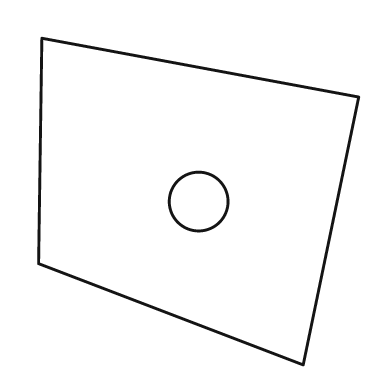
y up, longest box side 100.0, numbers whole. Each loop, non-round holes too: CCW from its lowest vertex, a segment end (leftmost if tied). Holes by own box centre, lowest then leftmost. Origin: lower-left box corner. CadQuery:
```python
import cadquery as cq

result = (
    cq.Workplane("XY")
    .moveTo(81.0, 0.0)
    .lineTo(98.0, 82.0)
    .lineTo(1.0, 100.0)
    .lineTo(0.0, 31.0)
    .close()
    .moveTo(49.0, 50.0)
    .circle(9.0)
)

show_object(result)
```